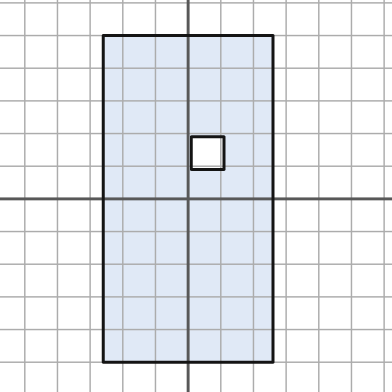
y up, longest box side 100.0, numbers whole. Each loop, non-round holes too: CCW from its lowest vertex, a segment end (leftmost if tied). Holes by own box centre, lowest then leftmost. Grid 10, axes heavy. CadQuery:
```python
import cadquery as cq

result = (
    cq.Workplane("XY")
    .moveTo(-26.0, -50.0)
    .lineTo(26.0, -50.0)
    .lineTo(26.0, 50.0)
    .lineTo(-26.0, 50.0)
    .close()
    .moveTo(1.0, 9.0)
    .lineTo(11.0, 9.0)
    .lineTo(11.0, 19.0)
    .lineTo(1.0, 19.0)
    .close()
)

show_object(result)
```